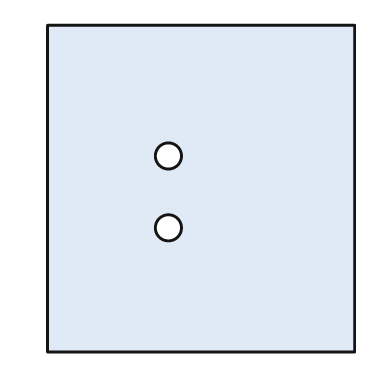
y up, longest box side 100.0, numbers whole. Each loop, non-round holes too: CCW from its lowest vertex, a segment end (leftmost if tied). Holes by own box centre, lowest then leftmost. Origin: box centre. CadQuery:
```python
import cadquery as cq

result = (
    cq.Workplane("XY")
    .moveTo(-47.0, -50.0)
    .lineTo(47.0, -50.0)
    .lineTo(47.0, 50.0)
    .lineTo(-47.0, 50.0)
    .close()
    .moveTo(-10.0, -12.0)
    .circle(4.0)
    .moveTo(-10.0, 10.0)
    .circle(4.0)
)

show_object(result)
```